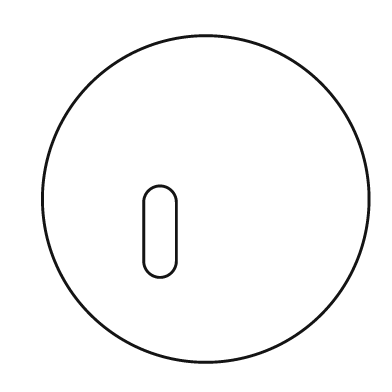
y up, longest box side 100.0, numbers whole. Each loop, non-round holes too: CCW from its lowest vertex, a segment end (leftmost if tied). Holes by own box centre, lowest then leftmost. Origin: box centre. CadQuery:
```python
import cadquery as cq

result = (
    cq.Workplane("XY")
    .moveTo(0.0, 0.0)
    .circle(50.0)
    .moveTo(-19.0, -19.0)
    .threePointArc((-14.0, -24.0), (-9.0, -19.0))
    .lineTo(-9.0, -1.0)
    .threePointArc((-14.0, 4.0), (-19.0, -1.0))
    .close()
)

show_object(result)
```